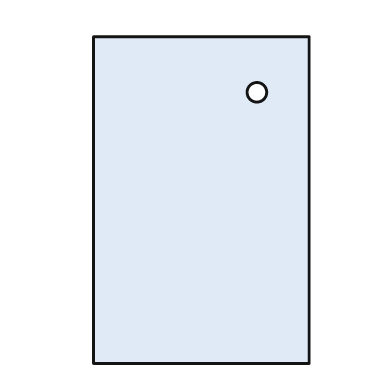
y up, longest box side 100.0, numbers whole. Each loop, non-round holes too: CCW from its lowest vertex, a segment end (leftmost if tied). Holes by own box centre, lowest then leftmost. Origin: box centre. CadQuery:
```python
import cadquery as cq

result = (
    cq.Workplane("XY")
    .moveTo(-33.0, -50.0)
    .lineTo(33.0, -50.0)
    .lineTo(33.0, 50.0)
    .lineTo(-33.0, 50.0)
    .close()
    .moveTo(17.0, 33.0)
    .circle(3.0)
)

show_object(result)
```